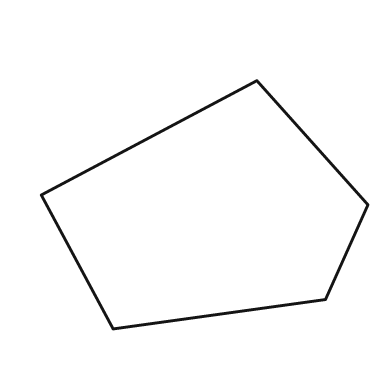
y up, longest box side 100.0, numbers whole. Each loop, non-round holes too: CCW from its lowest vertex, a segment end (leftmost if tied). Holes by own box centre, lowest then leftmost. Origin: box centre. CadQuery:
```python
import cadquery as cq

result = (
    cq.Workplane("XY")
    .moveTo(-28.0, -38.0)
    .lineTo(37.0, -29.0)
    .lineTo(50.0, 0.0)
    .lineTo(16.0, 38.0)
    .lineTo(-50.0, 3.0)
    .close()
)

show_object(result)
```